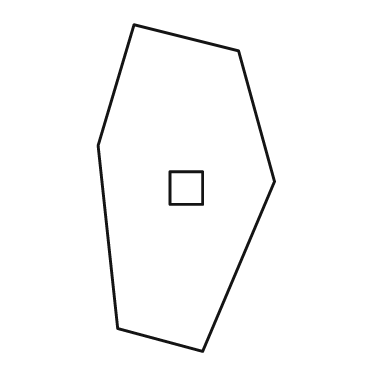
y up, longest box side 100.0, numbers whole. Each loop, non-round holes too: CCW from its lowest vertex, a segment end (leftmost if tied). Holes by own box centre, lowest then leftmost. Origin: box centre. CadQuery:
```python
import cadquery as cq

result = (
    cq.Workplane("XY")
    .moveTo(5.0, -50.0)
    .lineTo(27.0, 2.0)
    .lineTo(16.0, 42.0)
    .lineTo(-16.0, 50.0)
    .lineTo(-27.0, 13.0)
    .lineTo(-21.0, -43.0)
    .close()
    .moveTo(-5.0, -5.0)
    .lineTo(5.0, -5.0)
    .lineTo(5.0, 5.0)
    .lineTo(-5.0, 5.0)
    .close()
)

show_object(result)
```